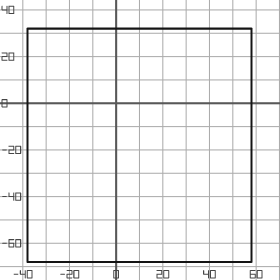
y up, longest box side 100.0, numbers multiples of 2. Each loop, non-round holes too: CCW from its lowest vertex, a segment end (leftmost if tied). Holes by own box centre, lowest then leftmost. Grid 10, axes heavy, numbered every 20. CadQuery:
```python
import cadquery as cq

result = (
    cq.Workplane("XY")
    .moveTo(-38.0, -68.0)
    .lineTo(58.0, -68.0)
    .lineTo(58.0, 32.0)
    .lineTo(-38.0, 32.0)
    .close()
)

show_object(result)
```